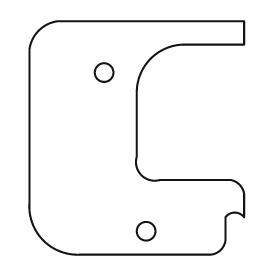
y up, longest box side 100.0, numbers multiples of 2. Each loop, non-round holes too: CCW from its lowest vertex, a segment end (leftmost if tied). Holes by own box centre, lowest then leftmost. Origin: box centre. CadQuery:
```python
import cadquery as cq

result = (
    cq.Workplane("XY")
    .moveTo(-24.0, -50.0)
    .lineTo(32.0, -50.0)
    .threePointArc((36.0, -48.0), (38.0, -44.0))
    .lineTo(38.0, -34.0)
    .threePointArc((42.0, -32.0), (46.0, -34.0))
    .lineTo(46.0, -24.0)
    .threePointArc((44.0, -20.0), (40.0, -18.0))
    .lineTo(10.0, -18.0)
    .threePointArc((2.0, -16.0), (0.0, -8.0))
    .lineTo(0.0, 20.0)
    .threePointArc((6.0, 34.0), (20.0, 40.0))
    .lineTo(46.0, 40.0)
    .lineTo(46.0, 50.0)
    .lineTo(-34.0, 50.0)
    .threePointArc((-42.0, 46.0), (-46.0, 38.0))
    .lineTo(-46.0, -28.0)
    .threePointArc((-40.0, -44.0), (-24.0, -50.0))
    .close()
    .moveTo(4.0, -40.0)
    .circle(4.0)
    .moveTo(-14.0, 28.0)
    .circle(4.0)
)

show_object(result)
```